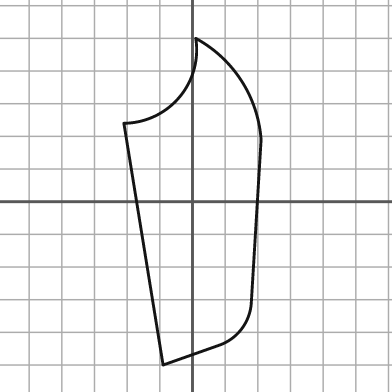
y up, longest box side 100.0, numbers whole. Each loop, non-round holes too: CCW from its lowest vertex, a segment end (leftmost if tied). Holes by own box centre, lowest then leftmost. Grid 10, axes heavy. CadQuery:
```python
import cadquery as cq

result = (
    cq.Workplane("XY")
    .moveTo(-9.0, -50.0)
    .lineTo(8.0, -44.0)
    .threePointArc((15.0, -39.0), (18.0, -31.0))
    .lineTo(21.0, 19.0)
    .threePointArc((15.0, 37.0), (1.0, 50.0))
    .threePointArc((-4.0, 32.0), (-21.0, 24.0))
    .close()
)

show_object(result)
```